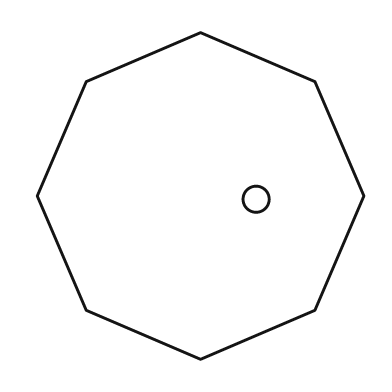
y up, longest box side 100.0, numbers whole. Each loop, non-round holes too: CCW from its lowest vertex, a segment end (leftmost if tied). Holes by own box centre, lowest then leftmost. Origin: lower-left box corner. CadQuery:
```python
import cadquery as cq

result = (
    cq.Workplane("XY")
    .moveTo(50.0, 0.0)
    .lineTo(85.0, 15.0)
    .lineTo(100.0, 50.0)
    .lineTo(85.0, 85.0)
    .lineTo(50.0, 100.0)
    .lineTo(15.0, 85.0)
    .lineTo(0.0, 50.0)
    .lineTo(15.0, 15.0)
    .close()
    .moveTo(67.0, 49.0)
    .circle(4.0)
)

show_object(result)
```